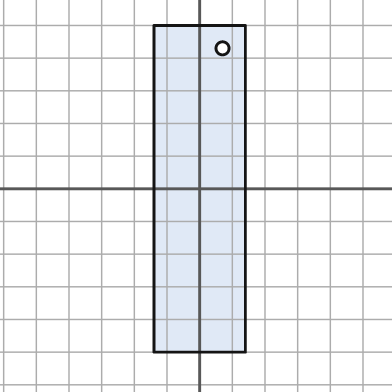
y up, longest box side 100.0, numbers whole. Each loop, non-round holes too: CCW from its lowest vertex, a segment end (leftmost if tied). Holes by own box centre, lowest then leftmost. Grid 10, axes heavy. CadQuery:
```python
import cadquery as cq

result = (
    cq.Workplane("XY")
    .moveTo(-14.0, -50.0)
    .lineTo(14.0, -50.0)
    .lineTo(14.0, 50.0)
    .lineTo(-14.0, 50.0)
    .close()
    .moveTo(7.0, 43.0)
    .circle(2.0)
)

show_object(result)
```